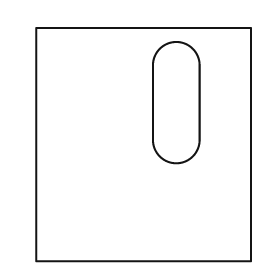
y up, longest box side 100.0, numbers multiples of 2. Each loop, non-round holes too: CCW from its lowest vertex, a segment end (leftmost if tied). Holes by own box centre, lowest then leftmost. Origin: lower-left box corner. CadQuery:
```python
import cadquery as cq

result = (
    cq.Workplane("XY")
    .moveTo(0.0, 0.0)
    .lineTo(92.0, 0.0)
    .lineTo(92.0, 100.0)
    .lineTo(0.0, 100.0)
    .close()
    .moveTo(50.0, 52.0)
    .threePointArc((60.0, 42.0), (70.0, 52.0))
    .lineTo(70.0, 84.0)
    .threePointArc((60.0, 94.0), (50.0, 84.0))
    .close()
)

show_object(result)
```